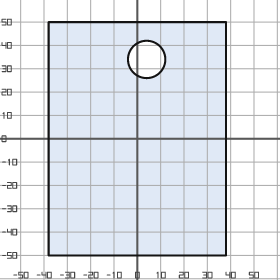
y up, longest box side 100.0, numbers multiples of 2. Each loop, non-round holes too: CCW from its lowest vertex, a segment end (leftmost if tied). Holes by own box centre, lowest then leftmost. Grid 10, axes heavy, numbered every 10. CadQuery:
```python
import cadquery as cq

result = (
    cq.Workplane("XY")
    .moveTo(-38.0, -50.0)
    .lineTo(38.0, -50.0)
    .lineTo(38.0, 50.0)
    .lineTo(-38.0, 50.0)
    .close()
    .moveTo(4.0, 34.0)
    .circle(8.0)
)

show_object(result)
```